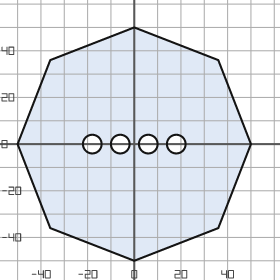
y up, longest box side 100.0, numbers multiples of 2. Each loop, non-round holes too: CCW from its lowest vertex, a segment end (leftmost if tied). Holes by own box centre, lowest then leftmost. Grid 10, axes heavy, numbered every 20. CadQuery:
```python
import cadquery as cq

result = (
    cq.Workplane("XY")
    .moveTo(0.0, -50.0)
    .lineTo(36.0, -36.0)
    .lineTo(50.0, 0.0)
    .lineTo(36.0, 36.0)
    .lineTo(0.0, 50.0)
    .lineTo(-36.0, 36.0)
    .lineTo(-50.0, 0.0)
    .lineTo(-36.0, -36.0)
    .close()
    .moveTo(-18.0, 0.0)
    .circle(4.0)
    .moveTo(-6.0, 0.0)
    .circle(4.0)
    .moveTo(6.0, 0.0)
    .circle(4.0)
    .moveTo(18.0, 0.0)
    .circle(4.0)
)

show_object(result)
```